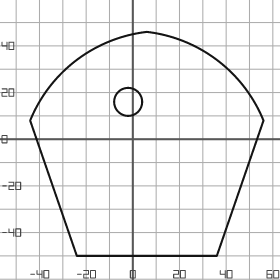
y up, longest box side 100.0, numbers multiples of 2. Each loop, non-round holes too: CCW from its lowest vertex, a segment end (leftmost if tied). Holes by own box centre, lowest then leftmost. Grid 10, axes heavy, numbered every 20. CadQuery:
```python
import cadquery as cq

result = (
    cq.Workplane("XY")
    .moveTo(-24.0, -50.0)
    .lineTo(36.0, -50.0)
    .lineTo(56.0, 8.0)
    .threePointArc((36.0, 34.0), (6.0, 46.0))
    .threePointArc((-24.0, 34.0), (-44.0, 8.0))
    .close()
    .moveTo(-2.0, 16.0)
    .circle(6.0)
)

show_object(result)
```